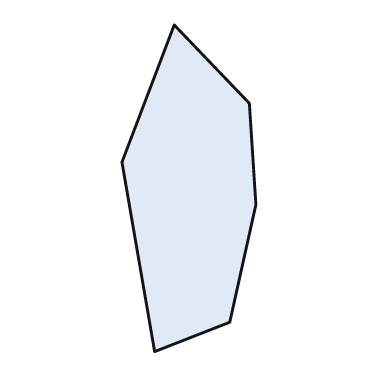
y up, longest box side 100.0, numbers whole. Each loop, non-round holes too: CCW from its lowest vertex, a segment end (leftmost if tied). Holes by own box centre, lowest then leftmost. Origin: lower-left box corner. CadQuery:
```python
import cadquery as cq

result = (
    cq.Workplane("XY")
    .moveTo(10.0, 0.0)
    .lineTo(33.0, 9.0)
    .lineTo(41.0, 45.0)
    .lineTo(39.0, 76.0)
    .lineTo(16.0, 100.0)
    .lineTo(0.0, 58.0)
    .close()
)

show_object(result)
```